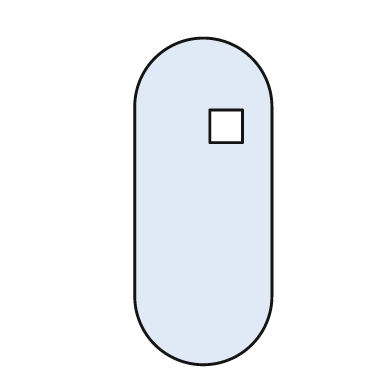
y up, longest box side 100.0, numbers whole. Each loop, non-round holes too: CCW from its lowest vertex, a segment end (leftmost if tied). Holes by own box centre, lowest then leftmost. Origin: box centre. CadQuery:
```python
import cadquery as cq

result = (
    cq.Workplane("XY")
    .moveTo(-21.0, -29.0)
    .threePointArc((0.0, -50.0), (21.0, -29.0))
    .lineTo(21.0, 29.0)
    .threePointArc((0.0, 50.0), (-21.0, 29.0))
    .close()
    .moveTo(2.0, 18.0)
    .lineTo(12.0, 18.0)
    .lineTo(12.0, 28.0)
    .lineTo(2.0, 28.0)
    .close()
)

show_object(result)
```